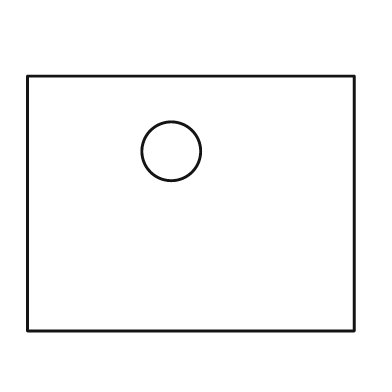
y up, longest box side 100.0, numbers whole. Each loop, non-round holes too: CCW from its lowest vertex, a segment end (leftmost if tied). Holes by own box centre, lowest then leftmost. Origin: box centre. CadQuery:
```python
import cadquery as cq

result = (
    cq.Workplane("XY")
    .moveTo(-50.0, -39.0)
    .lineTo(50.0, -39.0)
    .lineTo(50.0, 39.0)
    .lineTo(-50.0, 39.0)
    .close()
    .moveTo(-6.0, 16.0)
    .circle(9.0)
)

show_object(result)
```